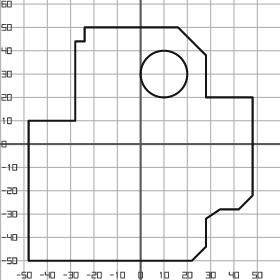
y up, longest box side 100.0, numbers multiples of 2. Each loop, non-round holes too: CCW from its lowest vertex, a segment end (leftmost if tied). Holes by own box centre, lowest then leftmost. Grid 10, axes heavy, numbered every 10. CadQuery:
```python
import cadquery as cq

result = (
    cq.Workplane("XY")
    .moveTo(-48.0, -50.0)
    .lineTo(22.0, -50.0)
    .lineTo(28.0, -44.0)
    .lineTo(28.0, -32.0)
    .lineTo(34.0, -28.0)
    .lineTo(42.0, -28.0)
    .lineTo(48.0, -22.0)
    .lineTo(48.0, 20.0)
    .lineTo(28.0, 20.0)
    .lineTo(28.0, 38.0)
    .lineTo(16.0, 50.0)
    .lineTo(-24.0, 50.0)
    .lineTo(-24.0, 44.0)
    .lineTo(-28.0, 44.0)
    .lineTo(-28.0, 10.0)
    .lineTo(-48.0, 10.0)
    .close()
    .moveTo(10.0, 30.0)
    .circle(10.0)
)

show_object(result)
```